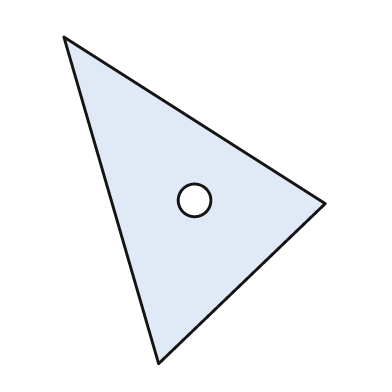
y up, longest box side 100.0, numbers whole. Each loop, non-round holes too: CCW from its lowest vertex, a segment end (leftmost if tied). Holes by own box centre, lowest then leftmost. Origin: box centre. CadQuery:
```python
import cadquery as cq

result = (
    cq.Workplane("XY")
    .moveTo(-11.0, -50.0)
    .lineTo(40.0, -1.0)
    .lineTo(-40.0, 50.0)
    .close()
    .moveTo(0.0, 0.0)
    .circle(5.0)
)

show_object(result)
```